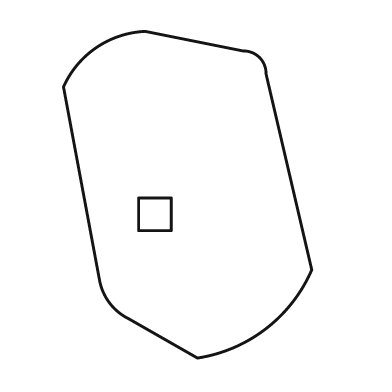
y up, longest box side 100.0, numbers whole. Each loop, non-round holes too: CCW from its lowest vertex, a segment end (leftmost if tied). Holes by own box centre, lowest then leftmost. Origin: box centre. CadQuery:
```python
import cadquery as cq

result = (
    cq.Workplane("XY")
    .moveTo(3.0, -50.0)
    .threePointArc((24.0, -41.0), (38.0, -23.0))
    .lineTo(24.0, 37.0)
    .threePointArc((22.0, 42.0), (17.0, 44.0))
    .lineTo(-13.0, 50.0)
    .threePointArc((-28.0, 45.0), (-38.0, 33.0))
    .lineTo(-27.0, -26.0)
    .threePointArc((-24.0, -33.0), (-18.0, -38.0))
    .close()
    .moveTo(-15.0, -11.0)
    .lineTo(-5.0, -11.0)
    .lineTo(-5.0, -1.0)
    .lineTo(-15.0, -1.0)
    .close()
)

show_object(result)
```